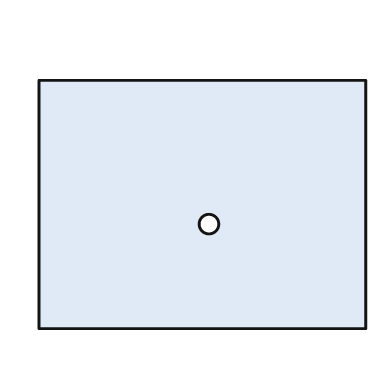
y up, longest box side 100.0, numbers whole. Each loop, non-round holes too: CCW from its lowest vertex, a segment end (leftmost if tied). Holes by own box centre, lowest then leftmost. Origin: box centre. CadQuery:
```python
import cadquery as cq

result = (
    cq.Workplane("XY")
    .moveTo(-50.0, -38.0)
    .lineTo(50.0, -38.0)
    .lineTo(50.0, 38.0)
    .lineTo(-50.0, 38.0)
    .close()
    .moveTo(2.0, -6.0)
    .circle(3.0)
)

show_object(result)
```